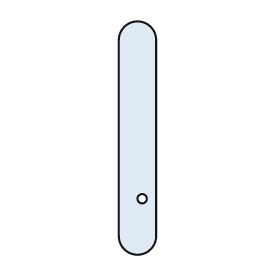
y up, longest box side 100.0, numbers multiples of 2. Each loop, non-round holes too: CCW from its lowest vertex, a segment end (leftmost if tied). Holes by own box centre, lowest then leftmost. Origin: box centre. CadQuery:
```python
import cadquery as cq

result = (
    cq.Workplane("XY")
    .moveTo(-8.0, -42.0)
    .threePointArc((0.0, -50.0), (8.0, -42.0))
    .lineTo(8.0, 42.0)
    .threePointArc((0.0, 50.0), (-8.0, 42.0))
    .close()
    .moveTo(2.0, -26.0)
    .circle(2.0)
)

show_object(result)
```